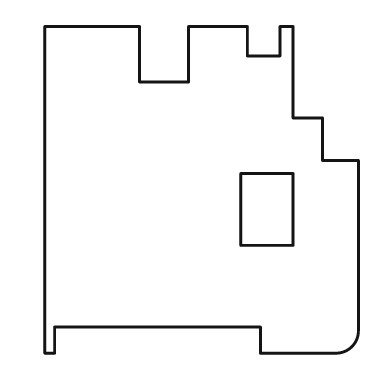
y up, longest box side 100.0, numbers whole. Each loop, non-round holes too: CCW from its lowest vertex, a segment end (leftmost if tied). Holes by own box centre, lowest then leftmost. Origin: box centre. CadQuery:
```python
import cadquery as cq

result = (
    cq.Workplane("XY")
    .moveTo(-48.0, -50.0)
    .lineTo(-45.0, -50.0)
    .lineTo(-45.0, -42.0)
    .lineTo(18.0, -42.0)
    .lineTo(18.0, -50.0)
    .lineTo(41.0, -50.0)
    .threePointArc((46.0, -48.0), (48.0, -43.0))
    .lineTo(48.0, 9.0)
    .lineTo(37.0, 9.0)
    .lineTo(37.0, 22.0)
    .lineTo(28.0, 22.0)
    .lineTo(28.0, 50.0)
    .lineTo(24.0, 50.0)
    .lineTo(24.0, 41.0)
    .lineTo(14.0, 41.0)
    .lineTo(14.0, 50.0)
    .lineTo(-4.0, 50.0)
    .lineTo(-4.0, 33.0)
    .lineTo(-19.0, 33.0)
    .lineTo(-19.0, 50.0)
    .lineTo(-48.0, 50.0)
    .close()
    .moveTo(12.0, -17.0)
    .lineTo(28.0, -17.0)
    .lineTo(28.0, 5.0)
    .lineTo(12.0, 5.0)
    .close()
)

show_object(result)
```